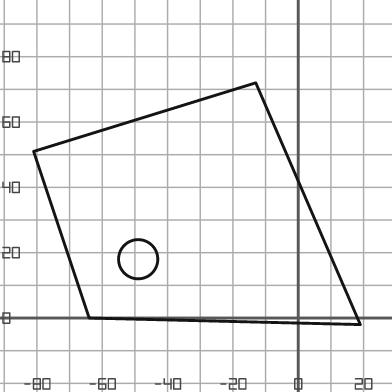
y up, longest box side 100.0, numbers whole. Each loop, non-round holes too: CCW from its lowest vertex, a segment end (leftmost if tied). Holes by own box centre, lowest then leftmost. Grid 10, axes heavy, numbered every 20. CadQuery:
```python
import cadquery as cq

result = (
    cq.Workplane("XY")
    .moveTo(19.0, -2.0)
    .lineTo(-13.0, 72.0)
    .lineTo(-81.0, 51.0)
    .lineTo(-64.0, 0.0)
    .close()
    .moveTo(-49.0, 18.0)
    .circle(6.0)
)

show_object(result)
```